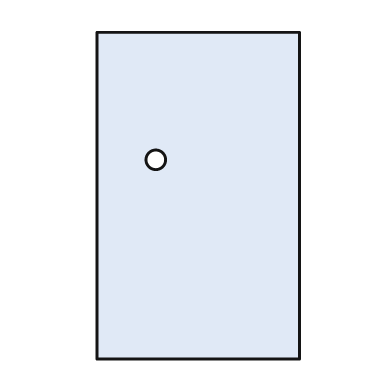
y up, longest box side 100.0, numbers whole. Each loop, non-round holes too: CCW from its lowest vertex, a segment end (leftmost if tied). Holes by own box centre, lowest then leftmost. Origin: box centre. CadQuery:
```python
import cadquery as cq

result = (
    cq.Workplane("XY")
    .moveTo(-31.0, -50.0)
    .lineTo(31.0, -50.0)
    .lineTo(31.0, 50.0)
    .lineTo(-31.0, 50.0)
    .close()
    .moveTo(-13.0, 11.0)
    .circle(3.0)
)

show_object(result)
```